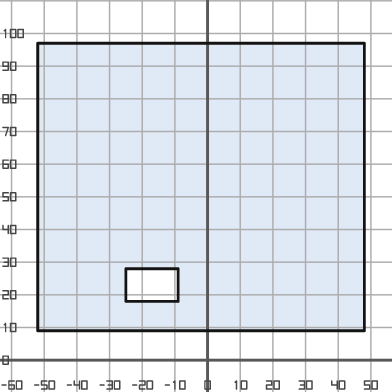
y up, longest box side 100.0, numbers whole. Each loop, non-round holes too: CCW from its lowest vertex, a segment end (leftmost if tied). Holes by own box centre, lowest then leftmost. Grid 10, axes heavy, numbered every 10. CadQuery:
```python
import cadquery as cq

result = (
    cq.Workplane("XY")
    .moveTo(-52.0, 9.0)
    .lineTo(48.0, 9.0)
    .lineTo(48.0, 97.0)
    .lineTo(-52.0, 97.0)
    .close()
    .moveTo(-25.0, 18.0)
    .lineTo(-9.0, 18.0)
    .lineTo(-9.0, 28.0)
    .lineTo(-25.0, 28.0)
    .close()
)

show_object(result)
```